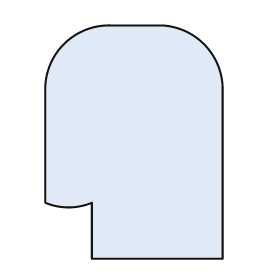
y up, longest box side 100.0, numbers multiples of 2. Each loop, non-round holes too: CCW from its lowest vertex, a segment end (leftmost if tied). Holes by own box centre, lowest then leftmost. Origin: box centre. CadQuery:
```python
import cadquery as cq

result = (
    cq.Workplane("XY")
    .moveTo(-18.0, -50.0)
    .lineTo(38.0, -50.0)
    .lineTo(38.0, 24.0)
    .threePointArc((30.0, 42.0), (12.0, 50.0))
    .lineTo(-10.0, 50.0)
    .threePointArc((-30.0, 42.0), (-38.0, 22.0))
    .lineTo(-38.0, -26.0)
    .threePointArc((-28.0, -28.0), (-18.0, -26.0))
    .close()
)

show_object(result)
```